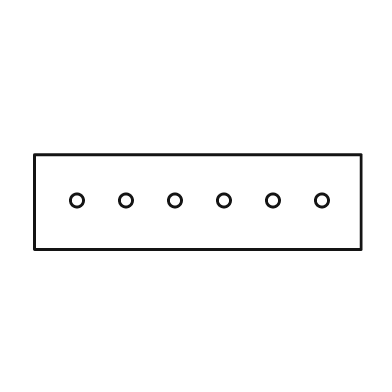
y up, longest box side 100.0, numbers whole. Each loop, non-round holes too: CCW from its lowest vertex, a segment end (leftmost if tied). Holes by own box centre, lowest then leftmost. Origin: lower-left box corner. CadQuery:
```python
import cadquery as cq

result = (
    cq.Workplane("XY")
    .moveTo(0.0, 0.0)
    .lineTo(100.0, 0.0)
    .lineTo(100.0, 29.0)
    .lineTo(0.0, 29.0)
    .close()
    .moveTo(13.0, 15.0)
    .circle(2.0)
    .moveTo(28.0, 15.0)
    .circle(2.0)
    .moveTo(43.0, 15.0)
    .circle(2.0)
    .moveTo(58.0, 15.0)
    .circle(2.0)
    .moveTo(73.0, 15.0)
    .circle(2.0)
    .moveTo(88.0, 15.0)
    .circle(2.0)
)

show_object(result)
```